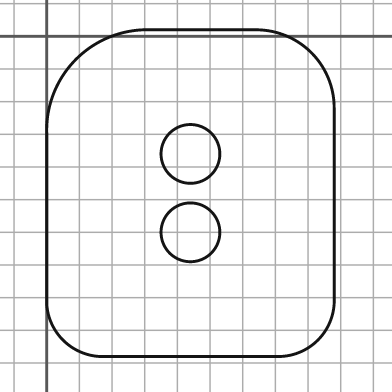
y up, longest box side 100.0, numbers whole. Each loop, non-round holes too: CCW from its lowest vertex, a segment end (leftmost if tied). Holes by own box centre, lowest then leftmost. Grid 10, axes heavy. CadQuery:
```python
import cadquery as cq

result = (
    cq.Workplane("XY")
    .moveTo(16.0, -98.0)
    .lineTo(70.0, -98.0)
    .threePointArc((83.0, -93.0), (88.0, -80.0))
    .lineTo(88.0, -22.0)
    .threePointArc((81.0, -5.0), (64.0, 2.0))
    .lineTo(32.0, 2.0)
    .threePointArc((9.0, -7.0), (0.0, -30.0))
    .lineTo(0.0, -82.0)
    .threePointArc((5.0, -93.0), (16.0, -98.0))
    .close()
    .moveTo(44.0, -60.0)
    .circle(9.0)
    .moveTo(44.0, -36.0)
    .circle(9.0)
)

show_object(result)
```